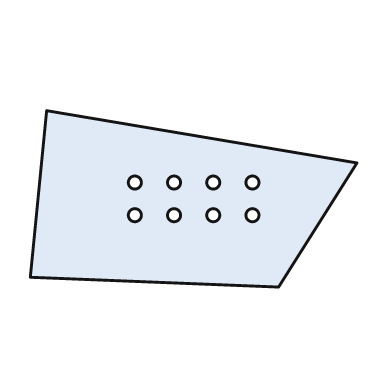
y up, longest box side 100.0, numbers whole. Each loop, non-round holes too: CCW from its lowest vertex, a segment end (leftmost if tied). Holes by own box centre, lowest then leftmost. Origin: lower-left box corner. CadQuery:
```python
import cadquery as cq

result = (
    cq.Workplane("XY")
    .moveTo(76.0, 0.0)
    .lineTo(100.0, 38.0)
    .lineTo(5.0, 54.0)
    .lineTo(0.0, 3.0)
    .close()
    .moveTo(32.0, 22.0)
    .circle(2.0)
    .moveTo(44.0, 22.0)
    .circle(2.0)
    .moveTo(56.0, 22.0)
    .circle(2.0)
    .moveTo(68.0, 22.0)
    .circle(2.0)
    .moveTo(32.0, 32.0)
    .circle(2.0)
    .moveTo(44.0, 32.0)
    .circle(2.0)
    .moveTo(56.0, 32.0)
    .circle(2.0)
    .moveTo(68.0, 32.0)
    .circle(2.0)
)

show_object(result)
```